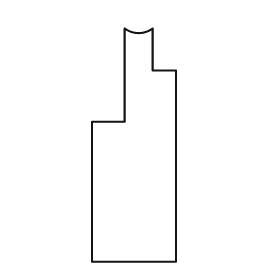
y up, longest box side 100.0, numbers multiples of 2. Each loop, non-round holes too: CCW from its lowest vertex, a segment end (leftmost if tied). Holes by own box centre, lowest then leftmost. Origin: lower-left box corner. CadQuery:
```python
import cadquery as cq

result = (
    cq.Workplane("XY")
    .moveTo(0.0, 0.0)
    .lineTo(36.0, 0.0)
    .lineTo(36.0, 82.0)
    .lineTo(26.0, 82.0)
    .lineTo(26.0, 100.0)
    .threePointArc((20.0, 98.0), (14.0, 100.0))
    .lineTo(14.0, 60.0)
    .lineTo(0.0, 60.0)
    .close()
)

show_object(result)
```